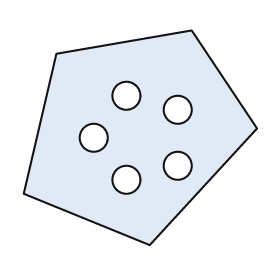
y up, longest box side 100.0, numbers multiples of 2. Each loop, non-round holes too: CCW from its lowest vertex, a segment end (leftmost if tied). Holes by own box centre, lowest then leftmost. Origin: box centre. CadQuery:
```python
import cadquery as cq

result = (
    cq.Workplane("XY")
    .moveTo(4.0, -46.0)
    .lineTo(50.0, 4.0)
    .lineTo(22.0, 46.0)
    .lineTo(-36.0, 36.0)
    .lineTo(-50.0, -24.0)
    .close()
    .moveTo(-6.0, -18.0)
    .circle(6.0)
    .moveTo(16.0, -12.0)
    .circle(6.0)
    .moveTo(-20.0, 0.0)
    .circle(6.0)
    .moveTo(16.0, 12.0)
    .circle(6.0)
    .moveTo(-6.0, 18.0)
    .circle(6.0)
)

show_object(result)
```